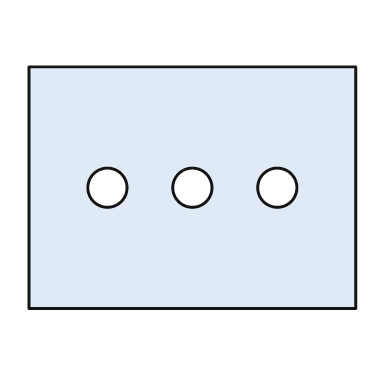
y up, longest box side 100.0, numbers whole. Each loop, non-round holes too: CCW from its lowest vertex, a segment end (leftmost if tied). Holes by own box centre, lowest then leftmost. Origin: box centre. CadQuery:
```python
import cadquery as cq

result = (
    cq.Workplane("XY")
    .moveTo(-50.0, -37.0)
    .lineTo(50.0, -37.0)
    .lineTo(50.0, 37.0)
    .lineTo(-50.0, 37.0)
    .close()
    .moveTo(-26.0, 0.0)
    .circle(6.0)
    .moveTo(0.0, 0.0)
    .circle(6.0)
    .moveTo(26.0, 0.0)
    .circle(6.0)
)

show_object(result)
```